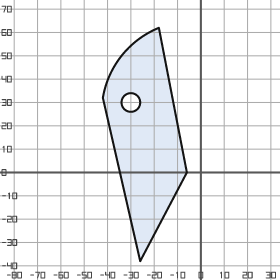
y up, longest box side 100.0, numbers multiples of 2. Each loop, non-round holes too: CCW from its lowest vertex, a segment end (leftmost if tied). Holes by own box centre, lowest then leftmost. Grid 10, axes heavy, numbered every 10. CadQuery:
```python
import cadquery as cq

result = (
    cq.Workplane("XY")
    .moveTo(-26.0, -38.0)
    .lineTo(-6.0, 0.0)
    .lineTo(-18.0, 62.0)
    .threePointArc((-34.0, 50.0), (-42.0, 32.0))
    .close()
    .moveTo(-30.0, 30.0)
    .circle(4.0)
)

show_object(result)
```